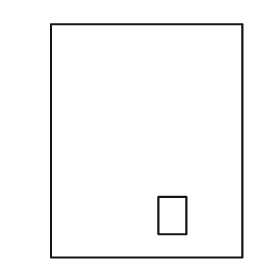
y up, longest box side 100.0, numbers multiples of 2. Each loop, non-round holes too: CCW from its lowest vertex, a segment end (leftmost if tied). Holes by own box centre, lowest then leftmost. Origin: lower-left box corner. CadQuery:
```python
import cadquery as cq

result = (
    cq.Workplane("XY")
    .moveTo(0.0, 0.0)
    .lineTo(82.0, 0.0)
    .lineTo(82.0, 100.0)
    .lineTo(0.0, 100.0)
    .close()
    .moveTo(46.0, 10.0)
    .lineTo(58.0, 10.0)
    .lineTo(58.0, 26.0)
    .lineTo(46.0, 26.0)
    .close()
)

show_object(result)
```